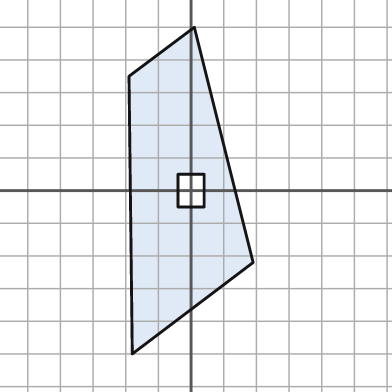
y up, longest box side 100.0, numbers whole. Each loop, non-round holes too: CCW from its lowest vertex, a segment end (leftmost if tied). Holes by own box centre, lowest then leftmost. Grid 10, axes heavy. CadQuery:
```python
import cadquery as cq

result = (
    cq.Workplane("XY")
    .moveTo(-18.0, -50.0)
    .lineTo(19.0, -22.0)
    .lineTo(1.0, 50.0)
    .lineTo(-19.0, 35.0)
    .close()
    .moveTo(-4.0, -5.0)
    .lineTo(4.0, -5.0)
    .lineTo(4.0, 5.0)
    .lineTo(-4.0, 5.0)
    .close()
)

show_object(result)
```